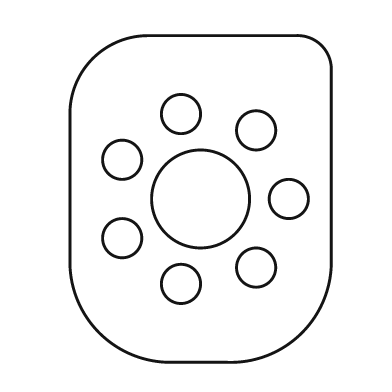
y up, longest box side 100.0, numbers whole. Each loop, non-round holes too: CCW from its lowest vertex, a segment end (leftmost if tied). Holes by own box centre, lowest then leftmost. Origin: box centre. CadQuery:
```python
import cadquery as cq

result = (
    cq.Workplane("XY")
    .moveTo(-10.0, -50.0)
    .lineTo(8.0, -50.0)
    .threePointArc((31.0, -41.0), (40.0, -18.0))
    .lineTo(40.0, 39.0)
    .threePointArc((37.0, 47.0), (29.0, 50.0))
    .lineTo(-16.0, 50.0)
    .threePointArc((-33.0, 43.0), (-40.0, 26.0))
    .lineTo(-40.0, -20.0)
    .threePointArc((-31.0, -41.0), (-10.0, -50.0))
    .close()
    .moveTo(-6.0, -26.0)
    .circle(6.0)
    .moveTo(17.0, -21.0)
    .circle(6.0)
    .moveTo(-24.0, -12.0)
    .circle(6.0)
    .moveTo(0.0, 0.0)
    .circle(15.0)
    .moveTo(27.0, 0.0)
    .circle(6.0)
    .moveTo(-24.0, 12.0)
    .circle(6.0)
    .moveTo(17.0, 21.0)
    .circle(6.0)
    .moveTo(-6.0, 26.0)
    .circle(6.0)
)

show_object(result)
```